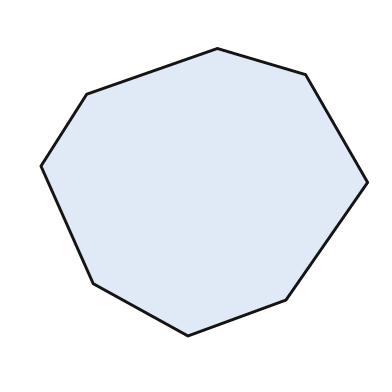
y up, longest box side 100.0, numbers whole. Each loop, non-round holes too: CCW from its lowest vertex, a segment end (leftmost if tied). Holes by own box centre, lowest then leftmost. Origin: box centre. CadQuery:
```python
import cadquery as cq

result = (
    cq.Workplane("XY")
    .moveTo(-5.0, -44.0)
    .lineTo(25.0, -33.0)
    .lineTo(50.0, 3.0)
    .lineTo(31.0, 36.0)
    .lineTo(4.0, 44.0)
    .lineTo(-36.0, 30.0)
    .lineTo(-50.0, 8.0)
    .lineTo(-34.0, -28.0)
    .close()
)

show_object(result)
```